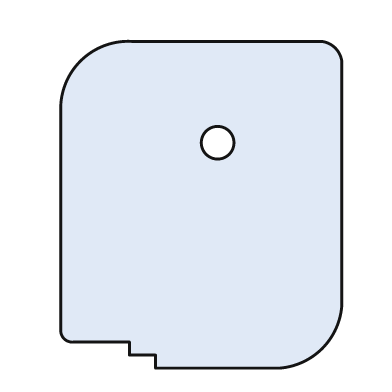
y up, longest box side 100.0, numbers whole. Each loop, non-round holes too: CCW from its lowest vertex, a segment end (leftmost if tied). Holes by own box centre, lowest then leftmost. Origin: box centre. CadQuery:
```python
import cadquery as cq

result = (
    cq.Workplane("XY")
    .moveTo(-14.0, -50.0)
    .lineTo(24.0, -50.0)
    .threePointArc((37.0, -44.0), (43.0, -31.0))
    .lineTo(43.0, 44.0)
    .threePointArc((41.0, 48.0), (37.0, 50.0))
    .lineTo(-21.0, 50.0)
    .threePointArc((-37.0, 44.0), (-43.0, 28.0))
    .lineTo(-43.0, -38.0)
    .threePointArc((-42.0, -41.0), (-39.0, -42.0))
    .lineTo(-22.0, -42.0)
    .lineTo(-22.0, -46.0)
    .lineTo(-14.0, -46.0)
    .close()
    .moveTo(5.0, 19.0)
    .circle(5.0)
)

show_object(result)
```